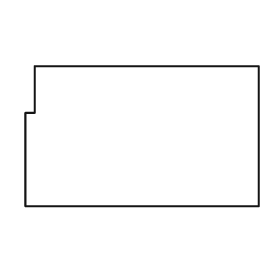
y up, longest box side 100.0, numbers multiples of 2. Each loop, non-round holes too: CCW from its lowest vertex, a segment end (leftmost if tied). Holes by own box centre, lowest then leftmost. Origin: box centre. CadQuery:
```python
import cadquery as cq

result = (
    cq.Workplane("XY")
    .moveTo(-50.0, -30.0)
    .lineTo(50.0, -30.0)
    .lineTo(50.0, 30.0)
    .lineTo(-46.0, 30.0)
    .lineTo(-46.0, 10.0)
    .lineTo(-50.0, 10.0)
    .close()
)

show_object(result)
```